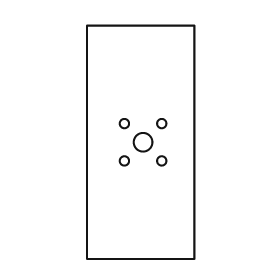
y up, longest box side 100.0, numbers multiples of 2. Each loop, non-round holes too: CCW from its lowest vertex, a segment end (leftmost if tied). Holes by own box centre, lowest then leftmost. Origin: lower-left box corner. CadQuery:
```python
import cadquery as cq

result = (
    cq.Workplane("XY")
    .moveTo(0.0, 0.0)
    .lineTo(46.0, 0.0)
    .lineTo(46.0, 100.0)
    .lineTo(0.0, 100.0)
    .close()
    .moveTo(16.0, 42.0)
    .circle(2.0)
    .moveTo(32.0, 42.0)
    .circle(2.0)
    .moveTo(24.0, 50.0)
    .circle(4.0)
    .moveTo(16.0, 58.0)
    .circle(2.0)
    .moveTo(32.0, 58.0)
    .circle(2.0)
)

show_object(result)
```